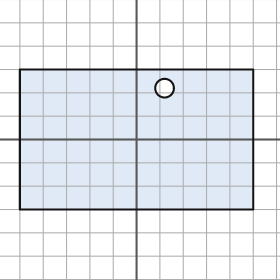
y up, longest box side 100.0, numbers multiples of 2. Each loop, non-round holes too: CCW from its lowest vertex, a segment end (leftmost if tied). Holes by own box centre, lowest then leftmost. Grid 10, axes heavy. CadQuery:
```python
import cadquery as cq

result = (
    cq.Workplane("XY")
    .moveTo(-50.0, -30.0)
    .lineTo(50.0, -30.0)
    .lineTo(50.0, 30.0)
    .lineTo(-50.0, 30.0)
    .close()
    .moveTo(12.0, 22.0)
    .circle(4.0)
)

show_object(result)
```